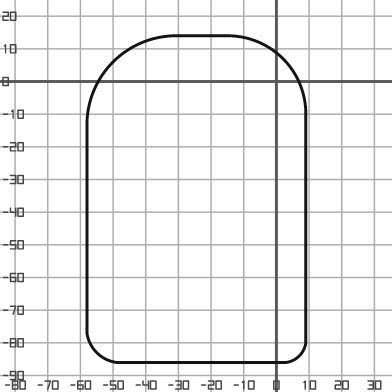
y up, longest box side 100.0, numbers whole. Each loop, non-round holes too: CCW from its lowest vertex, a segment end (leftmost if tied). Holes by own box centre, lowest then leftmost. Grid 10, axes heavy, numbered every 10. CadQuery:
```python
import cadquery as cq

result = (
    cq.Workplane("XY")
    .moveTo(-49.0, -86.0)
    .lineTo(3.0, -86.0)
    .threePointArc((7.0, -84.0), (9.0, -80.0))
    .lineTo(9.0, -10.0)
    .threePointArc((2.0, 7.0), (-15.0, 14.0))
    .lineTo(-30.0, 14.0)
    .threePointArc((-50.0, 6.0), (-58.0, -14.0))
    .lineTo(-58.0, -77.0)
    .threePointArc((-55.0, -83.0), (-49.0, -86.0))
    .close()
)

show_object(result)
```